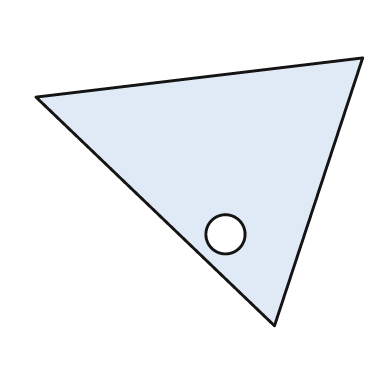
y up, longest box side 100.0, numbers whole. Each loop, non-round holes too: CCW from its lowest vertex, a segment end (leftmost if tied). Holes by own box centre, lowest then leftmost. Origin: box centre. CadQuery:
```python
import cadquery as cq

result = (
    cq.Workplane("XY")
    .moveTo(23.0, -41.0)
    .lineTo(50.0, 41.0)
    .lineTo(-50.0, 29.0)
    .close()
    .moveTo(8.0, -13.0)
    .circle(6.0)
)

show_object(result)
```